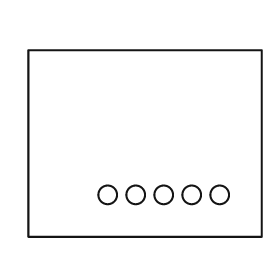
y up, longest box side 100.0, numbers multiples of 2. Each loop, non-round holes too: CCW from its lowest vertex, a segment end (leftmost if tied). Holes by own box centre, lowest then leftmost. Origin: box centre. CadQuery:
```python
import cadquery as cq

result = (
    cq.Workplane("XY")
    .moveTo(-50.0, -40.0)
    .lineTo(50.0, -40.0)
    .lineTo(50.0, 40.0)
    .lineTo(-50.0, 40.0)
    .close()
    .moveTo(-16.0, -22.0)
    .circle(4.0)
    .moveTo(-4.0, -22.0)
    .circle(4.0)
    .moveTo(8.0, -22.0)
    .circle(4.0)
    .moveTo(20.0, -22.0)
    .circle(4.0)
    .moveTo(32.0, -22.0)
    .circle(4.0)
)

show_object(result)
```